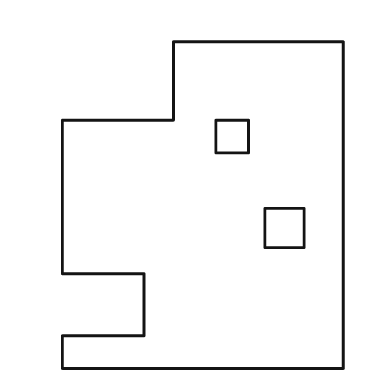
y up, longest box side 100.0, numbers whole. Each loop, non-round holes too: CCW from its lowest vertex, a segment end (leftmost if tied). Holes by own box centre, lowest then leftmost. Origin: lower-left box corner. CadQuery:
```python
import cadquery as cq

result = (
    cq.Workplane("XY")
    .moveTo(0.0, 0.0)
    .lineTo(86.0, 0.0)
    .lineTo(86.0, 100.0)
    .lineTo(34.0, 100.0)
    .lineTo(34.0, 76.0)
    .lineTo(0.0, 76.0)
    .lineTo(0.0, 29.0)
    .lineTo(25.0, 29.0)
    .lineTo(25.0, 10.0)
    .lineTo(0.0, 10.0)
    .close()
    .moveTo(62.0, 37.0)
    .lineTo(74.0, 37.0)
    .lineTo(74.0, 49.0)
    .lineTo(62.0, 49.0)
    .close()
    .moveTo(47.0, 66.0)
    .lineTo(57.0, 66.0)
    .lineTo(57.0, 76.0)
    .lineTo(47.0, 76.0)
    .close()
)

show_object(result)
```